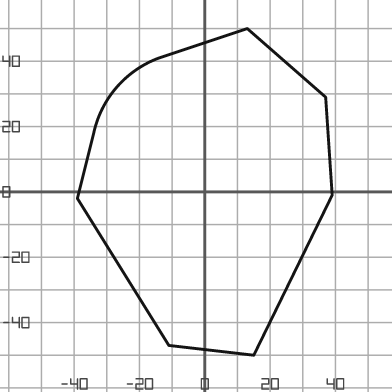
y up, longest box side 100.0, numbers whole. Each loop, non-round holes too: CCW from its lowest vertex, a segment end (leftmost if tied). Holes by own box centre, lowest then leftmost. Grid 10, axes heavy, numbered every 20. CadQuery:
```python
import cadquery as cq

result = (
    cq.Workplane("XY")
    .moveTo(15.0, -50.0)
    .lineTo(39.0, -1.0)
    .lineTo(37.0, 29.0)
    .lineTo(13.0, 50.0)
    .lineTo(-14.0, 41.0)
    .threePointArc((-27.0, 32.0), (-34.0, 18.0))
    .lineTo(-39.0, -2.0)
    .lineTo(-11.0, -47.0)
    .close()
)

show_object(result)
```